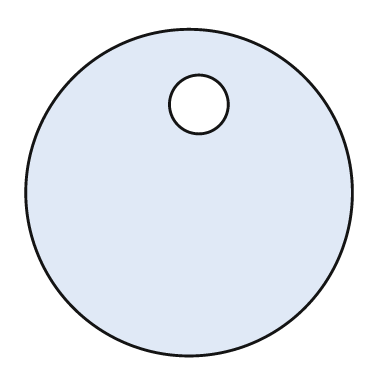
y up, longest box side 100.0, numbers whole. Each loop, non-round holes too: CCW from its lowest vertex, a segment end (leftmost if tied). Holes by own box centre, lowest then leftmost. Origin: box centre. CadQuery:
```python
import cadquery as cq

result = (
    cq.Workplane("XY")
    .moveTo(0.0, 0.0)
    .circle(50.0)
    .moveTo(3.0, 27.0)
    .circle(9.0)
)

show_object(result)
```